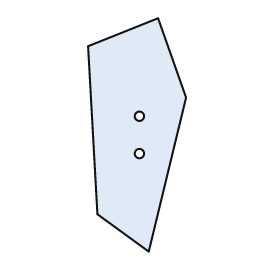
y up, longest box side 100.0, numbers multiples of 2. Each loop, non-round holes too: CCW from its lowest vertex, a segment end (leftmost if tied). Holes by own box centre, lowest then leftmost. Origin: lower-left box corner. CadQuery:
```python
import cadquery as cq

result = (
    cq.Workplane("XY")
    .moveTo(26.0, 0.0)
    .lineTo(42.0, 66.0)
    .lineTo(30.0, 100.0)
    .lineTo(0.0, 88.0)
    .lineTo(4.0, 16.0)
    .close()
    .moveTo(22.0, 42.0)
    .circle(2.0)
    .moveTo(22.0, 58.0)
    .circle(2.0)
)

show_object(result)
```